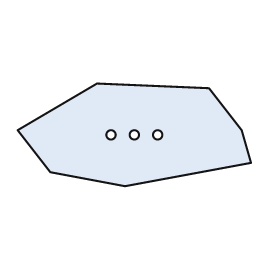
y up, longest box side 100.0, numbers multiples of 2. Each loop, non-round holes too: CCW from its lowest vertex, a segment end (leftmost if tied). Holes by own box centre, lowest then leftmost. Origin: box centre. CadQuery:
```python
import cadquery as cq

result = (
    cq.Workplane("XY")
    .moveTo(-4.0, -22.0)
    .lineTo(50.0, -12.0)
    .lineTo(46.0, 2.0)
    .lineTo(32.0, 20.0)
    .lineTo(-16.0, 22.0)
    .lineTo(-50.0, 2.0)
    .lineTo(-36.0, -16.0)
    .close()
    .moveTo(-10.0, 0.0)
    .circle(2.0)
    .moveTo(0.0, 0.0)
    .circle(2.0)
    .moveTo(10.0, 0.0)
    .circle(2.0)
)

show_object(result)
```